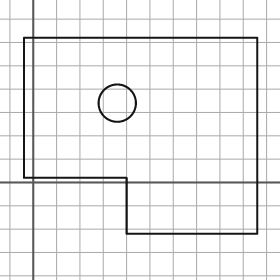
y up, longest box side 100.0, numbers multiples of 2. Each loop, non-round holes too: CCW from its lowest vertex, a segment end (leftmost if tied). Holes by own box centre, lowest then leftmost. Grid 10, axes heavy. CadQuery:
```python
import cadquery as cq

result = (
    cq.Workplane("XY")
    .moveTo(40.0, -22.0)
    .lineTo(96.0, -22.0)
    .lineTo(96.0, 62.0)
    .lineTo(-4.0, 62.0)
    .lineTo(-4.0, 2.0)
    .lineTo(40.0, 2.0)
    .close()
    .moveTo(36.0, 34.0)
    .circle(8.0)
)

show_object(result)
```